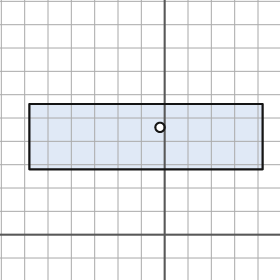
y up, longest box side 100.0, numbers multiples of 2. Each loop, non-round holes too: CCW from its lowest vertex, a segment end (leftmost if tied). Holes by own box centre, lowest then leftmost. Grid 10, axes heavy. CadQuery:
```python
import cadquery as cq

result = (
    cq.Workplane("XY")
    .moveTo(-58.0, 28.0)
    .lineTo(42.0, 28.0)
    .lineTo(42.0, 56.0)
    .lineTo(-58.0, 56.0)
    .close()
    .moveTo(-2.0, 46.0)
    .circle(2.0)
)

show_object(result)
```